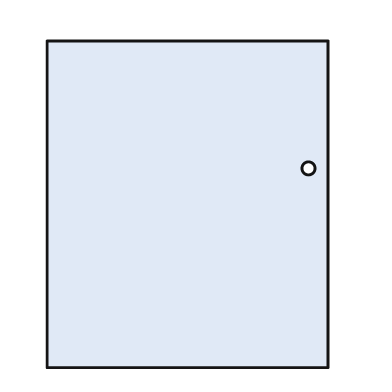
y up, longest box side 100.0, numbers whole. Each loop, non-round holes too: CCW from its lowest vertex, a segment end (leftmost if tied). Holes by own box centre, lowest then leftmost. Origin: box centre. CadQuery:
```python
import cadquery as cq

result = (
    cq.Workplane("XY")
    .moveTo(-43.0, -50.0)
    .lineTo(43.0, -50.0)
    .lineTo(43.0, 50.0)
    .lineTo(-43.0, 50.0)
    .close()
    .moveTo(37.0, 11.0)
    .circle(2.0)
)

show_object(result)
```